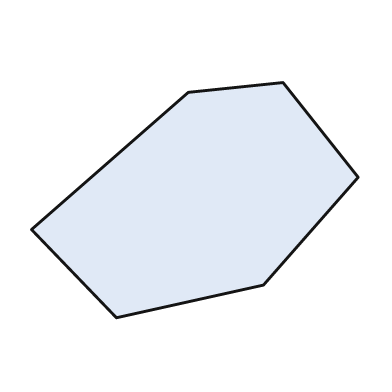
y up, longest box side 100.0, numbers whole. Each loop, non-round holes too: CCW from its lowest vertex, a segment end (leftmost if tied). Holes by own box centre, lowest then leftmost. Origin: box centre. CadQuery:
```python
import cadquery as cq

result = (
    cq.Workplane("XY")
    .moveTo(-24.0, -36.0)
    .lineTo(21.0, -26.0)
    .lineTo(50.0, 7.0)
    .lineTo(27.0, 36.0)
    .lineTo(-2.0, 33.0)
    .lineTo(-50.0, -9.0)
    .close()
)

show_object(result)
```